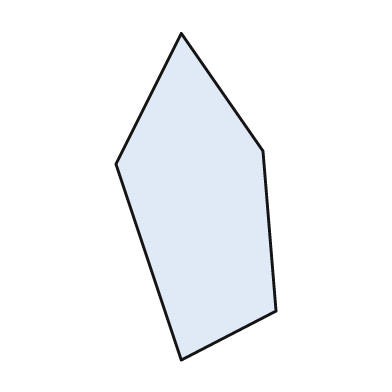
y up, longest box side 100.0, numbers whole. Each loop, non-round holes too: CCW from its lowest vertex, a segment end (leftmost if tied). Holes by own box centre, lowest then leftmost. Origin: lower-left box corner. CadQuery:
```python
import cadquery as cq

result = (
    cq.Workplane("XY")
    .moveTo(20.0, 0.0)
    .lineTo(49.0, 15.0)
    .lineTo(45.0, 64.0)
    .lineTo(20.0, 100.0)
    .lineTo(0.0, 60.0)
    .close()
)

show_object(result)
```